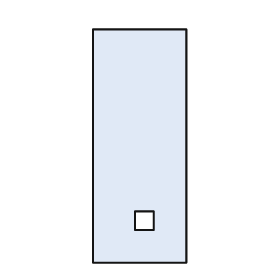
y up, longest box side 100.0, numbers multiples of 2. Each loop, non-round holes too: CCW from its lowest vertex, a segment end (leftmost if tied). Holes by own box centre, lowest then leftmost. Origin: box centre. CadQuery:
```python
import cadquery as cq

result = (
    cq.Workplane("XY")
    .moveTo(-20.0, -50.0)
    .lineTo(20.0, -50.0)
    .lineTo(20.0, 50.0)
    .lineTo(-20.0, 50.0)
    .close()
    .moveTo(-2.0, -36.0)
    .lineTo(6.0, -36.0)
    .lineTo(6.0, -28.0)
    .lineTo(-2.0, -28.0)
    .close()
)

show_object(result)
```